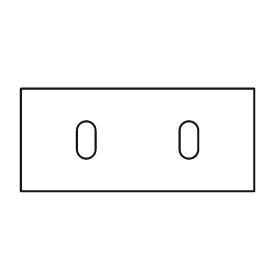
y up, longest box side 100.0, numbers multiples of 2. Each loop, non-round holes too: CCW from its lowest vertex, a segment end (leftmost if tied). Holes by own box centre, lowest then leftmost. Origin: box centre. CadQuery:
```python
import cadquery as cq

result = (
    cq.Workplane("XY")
    .moveTo(-50.0, -22.0)
    .lineTo(50.0, -22.0)
    .lineTo(50.0, 22.0)
    .lineTo(-50.0, 22.0)
    .close()
    .moveTo(-26.0, -4.0)
    .threePointArc((-22.0, -8.0), (-18.0, -4.0))
    .lineTo(-18.0, 4.0)
    .threePointArc((-22.0, 8.0), (-26.0, 4.0))
    .close()
    .moveTo(18.0, -4.0)
    .threePointArc((22.0, -8.0), (26.0, -4.0))
    .lineTo(26.0, 4.0)
    .threePointArc((22.0, 8.0), (18.0, 4.0))
    .close()
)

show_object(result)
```